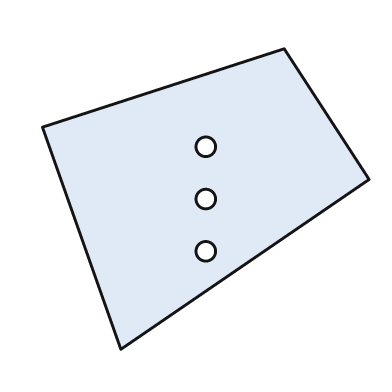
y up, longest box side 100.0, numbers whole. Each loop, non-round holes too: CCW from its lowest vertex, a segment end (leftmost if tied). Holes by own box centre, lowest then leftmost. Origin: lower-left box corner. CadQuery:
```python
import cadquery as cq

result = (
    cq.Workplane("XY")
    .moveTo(24.0, 0.0)
    .lineTo(100.0, 52.0)
    .lineTo(74.0, 92.0)
    .lineTo(0.0, 68.0)
    .close()
    .moveTo(50.0, 30.0)
    .circle(3.0)
    .moveTo(50.0, 46.0)
    .circle(3.0)
    .moveTo(50.0, 62.0)
    .circle(3.0)
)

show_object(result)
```